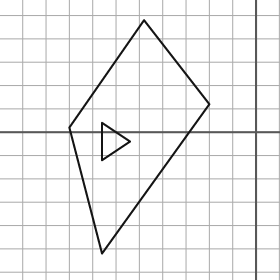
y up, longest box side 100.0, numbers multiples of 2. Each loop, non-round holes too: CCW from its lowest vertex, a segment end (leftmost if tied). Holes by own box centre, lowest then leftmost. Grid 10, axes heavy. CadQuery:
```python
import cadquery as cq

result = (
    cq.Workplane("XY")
    .moveTo(-66.0, -52.0)
    .lineTo(-20.0, 12.0)
    .lineTo(-48.0, 48.0)
    .lineTo(-80.0, 2.0)
    .close()
    .moveTo(-66.0, -12.0)
    .lineTo(-54.0, -4.0)
    .lineTo(-66.0, 4.0)
    .close()
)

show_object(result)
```